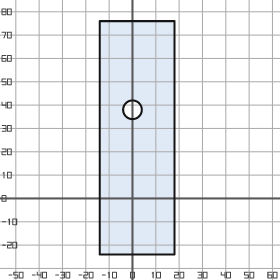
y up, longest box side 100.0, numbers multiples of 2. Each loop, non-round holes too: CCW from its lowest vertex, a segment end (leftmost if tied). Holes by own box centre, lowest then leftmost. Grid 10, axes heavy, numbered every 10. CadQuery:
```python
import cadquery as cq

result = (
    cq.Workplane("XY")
    .moveTo(-14.0, -24.0)
    .lineTo(18.0, -24.0)
    .lineTo(18.0, 76.0)
    .lineTo(-14.0, 76.0)
    .close()
    .moveTo(0.0, 38.0)
    .circle(4.0)
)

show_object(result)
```